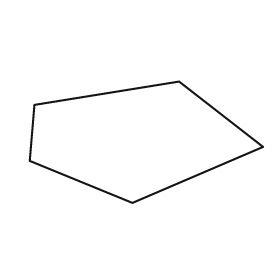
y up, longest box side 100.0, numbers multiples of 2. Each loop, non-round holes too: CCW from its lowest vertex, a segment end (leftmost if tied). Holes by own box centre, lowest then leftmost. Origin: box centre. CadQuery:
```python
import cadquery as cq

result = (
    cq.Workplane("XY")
    .moveTo(-6.0, -26.0)
    .lineTo(50.0, -2.0)
    .lineTo(14.0, 26.0)
    .lineTo(-48.0, 16.0)
    .lineTo(-50.0, -8.0)
    .close()
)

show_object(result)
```